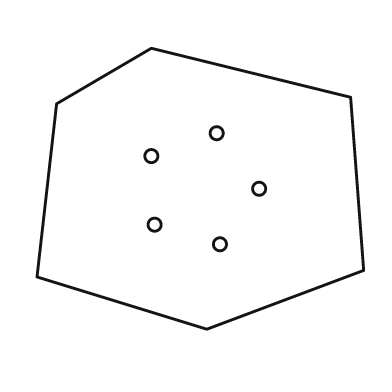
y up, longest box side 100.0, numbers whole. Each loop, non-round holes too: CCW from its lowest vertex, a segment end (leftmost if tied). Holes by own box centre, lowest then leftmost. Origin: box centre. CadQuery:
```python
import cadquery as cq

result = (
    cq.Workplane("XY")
    .moveTo(2.0, -43.0)
    .lineTo(50.0, -25.0)
    .lineTo(46.0, 28.0)
    .lineTo(-15.0, 43.0)
    .lineTo(-44.0, 26.0)
    .lineTo(-50.0, -27.0)
    .close()
    .moveTo(6.0, -17.0)
    .circle(2.0)
    .moveTo(-14.0, -11.0)
    .circle(2.0)
    .moveTo(18.0, 0.0)
    .circle(2.0)
    .moveTo(-15.0, 10.0)
    .circle(2.0)
    .moveTo(5.0, 17.0)
    .circle(2.0)
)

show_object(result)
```